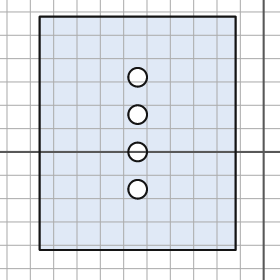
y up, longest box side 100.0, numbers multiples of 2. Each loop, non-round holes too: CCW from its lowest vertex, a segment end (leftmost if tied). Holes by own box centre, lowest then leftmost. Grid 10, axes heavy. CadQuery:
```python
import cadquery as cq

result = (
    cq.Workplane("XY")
    .moveTo(-96.0, -42.0)
    .lineTo(-12.0, -42.0)
    .lineTo(-12.0, 58.0)
    .lineTo(-96.0, 58.0)
    .close()
    .moveTo(-54.0, -16.0)
    .circle(4.0)
    .moveTo(-54.0, 0.0)
    .circle(4.0)
    .moveTo(-54.0, 16.0)
    .circle(4.0)
    .moveTo(-54.0, 32.0)
    .circle(4.0)
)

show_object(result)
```